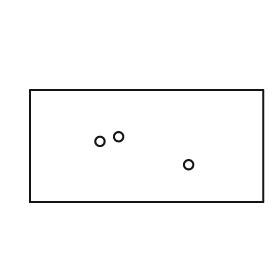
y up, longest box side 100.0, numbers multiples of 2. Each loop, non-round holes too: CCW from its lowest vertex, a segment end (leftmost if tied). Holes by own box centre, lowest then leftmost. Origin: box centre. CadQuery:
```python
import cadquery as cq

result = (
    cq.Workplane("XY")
    .moveTo(-50.0, -24.0)
    .lineTo(50.0, -24.0)
    .lineTo(50.0, 24.0)
    .lineTo(-50.0, 24.0)
    .close()
    .moveTo(18.0, -8.0)
    .circle(2.0)
    .moveTo(-20.0, 2.0)
    .circle(2.0)
    .moveTo(-12.0, 4.0)
    .circle(2.0)
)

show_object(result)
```